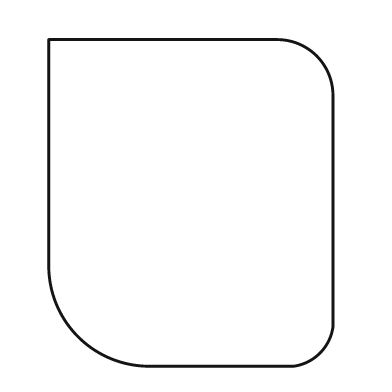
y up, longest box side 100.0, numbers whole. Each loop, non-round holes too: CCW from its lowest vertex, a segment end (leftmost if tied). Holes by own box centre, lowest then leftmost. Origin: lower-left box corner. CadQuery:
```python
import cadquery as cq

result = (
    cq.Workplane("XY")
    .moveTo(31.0, 0.0)
    .lineTo(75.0, 0.0)
    .threePointArc((83.0, 4.0), (87.0, 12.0))
    .lineTo(87.0, 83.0)
    .threePointArc((82.0, 95.0), (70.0, 100.0))
    .lineTo(0.0, 100.0)
    .lineTo(0.0, 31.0)
    .threePointArc((9.0, 9.0), (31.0, 0.0))
    .close()
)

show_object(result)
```